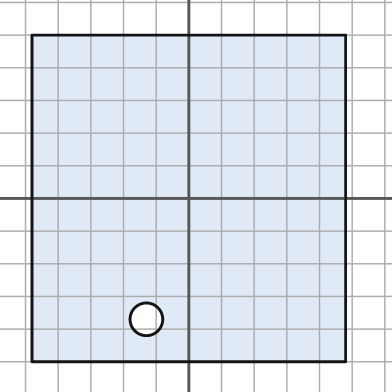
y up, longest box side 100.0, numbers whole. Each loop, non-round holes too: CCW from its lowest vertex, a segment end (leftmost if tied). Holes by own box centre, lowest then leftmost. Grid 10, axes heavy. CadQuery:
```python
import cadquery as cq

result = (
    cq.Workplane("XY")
    .moveTo(-48.0, -50.0)
    .lineTo(48.0, -50.0)
    .lineTo(48.0, 50.0)
    .lineTo(-48.0, 50.0)
    .close()
    .moveTo(-13.0, -37.0)
    .circle(5.0)
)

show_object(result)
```